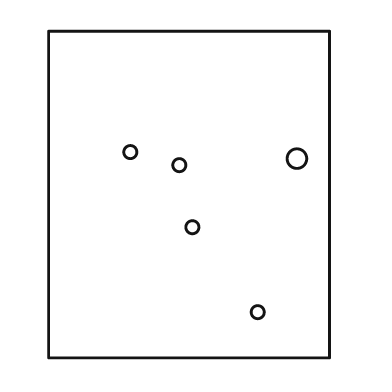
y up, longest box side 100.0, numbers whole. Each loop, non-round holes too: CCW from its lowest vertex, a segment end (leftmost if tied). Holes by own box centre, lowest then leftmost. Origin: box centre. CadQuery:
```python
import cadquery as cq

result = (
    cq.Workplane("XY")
    .moveTo(-43.0, -50.0)
    .lineTo(43.0, -50.0)
    .lineTo(43.0, 50.0)
    .lineTo(-43.0, 50.0)
    .close()
    .moveTo(21.0, -36.0)
    .circle(2.0)
    .moveTo(1.0, -10.0)
    .circle(2.0)
    .moveTo(-3.0, 9.0)
    .circle(2.0)
    .moveTo(33.0, 11.0)
    .circle(3.0)
    .moveTo(-18.0, 13.0)
    .circle(2.0)
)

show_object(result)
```